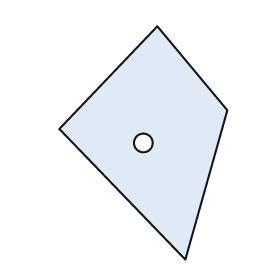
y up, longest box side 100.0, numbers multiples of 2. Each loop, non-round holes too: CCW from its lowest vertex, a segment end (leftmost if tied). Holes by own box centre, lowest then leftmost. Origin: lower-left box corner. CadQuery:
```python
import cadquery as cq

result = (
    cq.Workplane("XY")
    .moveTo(54.0, 0.0)
    .lineTo(72.0, 64.0)
    .lineTo(42.0, 100.0)
    .lineTo(0.0, 56.0)
    .close()
    .moveTo(36.0, 50.0)
    .circle(4.0)
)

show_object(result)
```